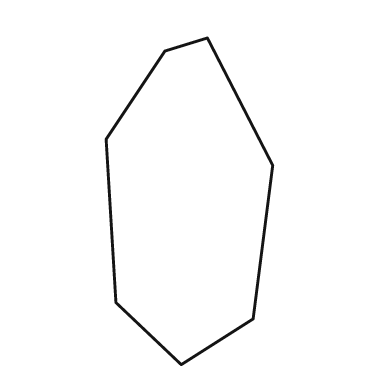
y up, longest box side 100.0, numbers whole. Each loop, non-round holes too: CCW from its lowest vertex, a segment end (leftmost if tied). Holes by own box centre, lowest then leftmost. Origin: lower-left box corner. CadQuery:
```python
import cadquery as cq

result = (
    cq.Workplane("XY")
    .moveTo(23.0, 0.0)
    .lineTo(45.0, 14.0)
    .lineTo(51.0, 61.0)
    .lineTo(31.0, 100.0)
    .lineTo(18.0, 96.0)
    .lineTo(0.0, 69.0)
    .lineTo(3.0, 19.0)
    .close()
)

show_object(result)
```